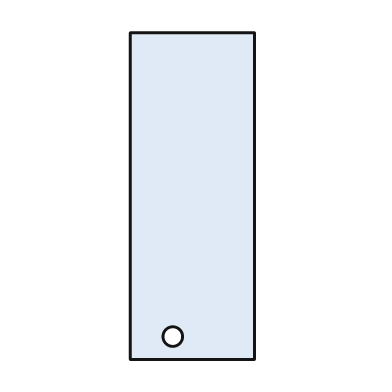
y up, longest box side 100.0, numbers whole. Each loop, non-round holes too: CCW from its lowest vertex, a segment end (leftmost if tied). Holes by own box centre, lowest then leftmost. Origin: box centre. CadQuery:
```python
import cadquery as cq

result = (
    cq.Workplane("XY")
    .moveTo(-19.0, -50.0)
    .lineTo(19.0, -50.0)
    .lineTo(19.0, 50.0)
    .lineTo(-19.0, 50.0)
    .close()
    .moveTo(-6.0, -43.0)
    .circle(3.0)
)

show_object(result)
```